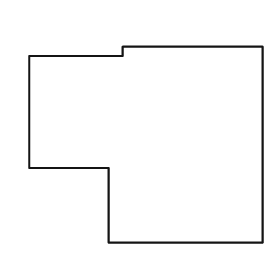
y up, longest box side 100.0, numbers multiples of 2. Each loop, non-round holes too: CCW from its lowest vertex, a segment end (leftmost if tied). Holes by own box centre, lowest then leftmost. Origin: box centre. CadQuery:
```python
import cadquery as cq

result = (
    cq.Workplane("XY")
    .moveTo(-16.0, -42.0)
    .lineTo(50.0, -42.0)
    .lineTo(50.0, 42.0)
    .lineTo(-10.0, 42.0)
    .lineTo(-10.0, 38.0)
    .lineTo(-50.0, 38.0)
    .lineTo(-50.0, -10.0)
    .lineTo(-16.0, -10.0)
    .close()
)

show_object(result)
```